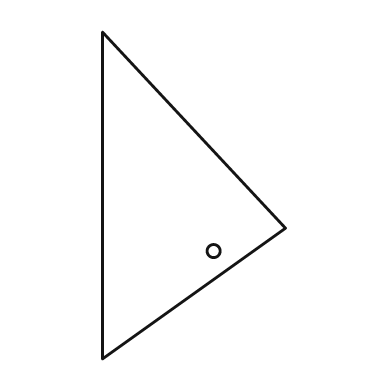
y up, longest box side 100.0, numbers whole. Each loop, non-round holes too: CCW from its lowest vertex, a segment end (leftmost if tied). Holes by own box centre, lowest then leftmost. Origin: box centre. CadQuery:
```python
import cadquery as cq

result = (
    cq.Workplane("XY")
    .moveTo(-28.0, -50.0)
    .lineTo(28.0, -10.0)
    .lineTo(-28.0, 50.0)
    .close()
    .moveTo(6.0, -17.0)
    .circle(2.0)
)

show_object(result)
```